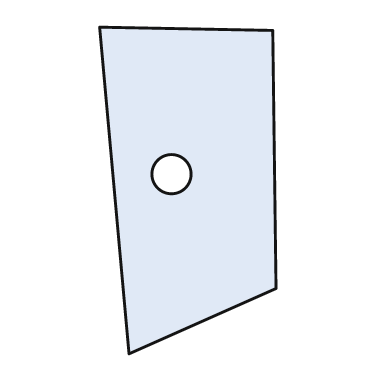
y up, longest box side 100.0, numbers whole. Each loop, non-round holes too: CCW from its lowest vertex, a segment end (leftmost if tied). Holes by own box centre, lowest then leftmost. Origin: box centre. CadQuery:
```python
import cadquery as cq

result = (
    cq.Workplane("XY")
    .moveTo(-18.0, -50.0)
    .lineTo(27.0, -30.0)
    .lineTo(26.0, 49.0)
    .lineTo(-27.0, 50.0)
    .close()
    .moveTo(-5.0, 5.0)
    .circle(6.0)
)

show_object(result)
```